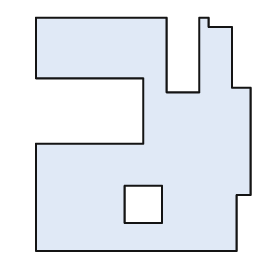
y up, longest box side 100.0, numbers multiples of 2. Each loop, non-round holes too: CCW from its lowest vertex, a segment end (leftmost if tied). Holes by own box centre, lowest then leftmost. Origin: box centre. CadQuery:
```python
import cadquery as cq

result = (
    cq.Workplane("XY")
    .moveTo(-46.0, -50.0)
    .lineTo(40.0, -50.0)
    .lineTo(40.0, -26.0)
    .lineTo(46.0, -26.0)
    .lineTo(46.0, 20.0)
    .lineTo(38.0, 20.0)
    .lineTo(38.0, 46.0)
    .lineTo(28.0, 46.0)
    .lineTo(28.0, 50.0)
    .lineTo(24.0, 50.0)
    .lineTo(24.0, 18.0)
    .lineTo(10.0, 18.0)
    .lineTo(10.0, 50.0)
    .lineTo(-46.0, 50.0)
    .lineTo(-46.0, 24.0)
    .lineTo(0.0, 24.0)
    .lineTo(0.0, -4.0)
    .lineTo(-46.0, -4.0)
    .close()
    .moveTo(-8.0, -38.0)
    .lineTo(8.0, -38.0)
    .lineTo(8.0, -22.0)
    .lineTo(-8.0, -22.0)
    .close()
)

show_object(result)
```